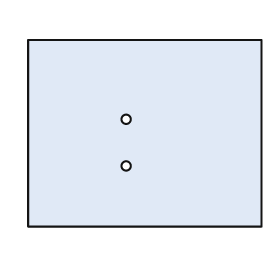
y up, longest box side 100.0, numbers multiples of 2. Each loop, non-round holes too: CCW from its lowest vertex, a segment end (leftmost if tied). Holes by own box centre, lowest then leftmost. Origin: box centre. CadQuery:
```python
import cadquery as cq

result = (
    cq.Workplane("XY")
    .moveTo(-50.0, -40.0)
    .lineTo(50.0, -40.0)
    .lineTo(50.0, 40.0)
    .lineTo(-50.0, 40.0)
    .close()
    .moveTo(-8.0, -14.0)
    .circle(2.0)
    .moveTo(-8.0, 6.0)
    .circle(2.0)
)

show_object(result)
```